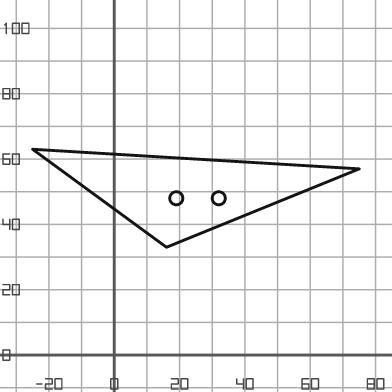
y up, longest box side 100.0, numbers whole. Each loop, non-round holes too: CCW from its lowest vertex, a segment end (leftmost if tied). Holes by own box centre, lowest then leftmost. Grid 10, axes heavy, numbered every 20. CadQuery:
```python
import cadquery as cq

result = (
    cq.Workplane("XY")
    .moveTo(16.0, 33.0)
    .lineTo(75.0, 57.0)
    .lineTo(-25.0, 63.0)
    .close()
    .moveTo(19.0, 48.0)
    .circle(2.0)
    .moveTo(32.0, 48.0)
    .circle(2.0)
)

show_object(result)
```